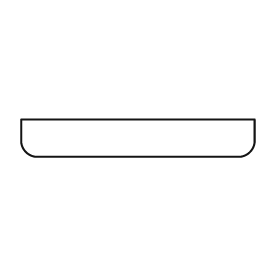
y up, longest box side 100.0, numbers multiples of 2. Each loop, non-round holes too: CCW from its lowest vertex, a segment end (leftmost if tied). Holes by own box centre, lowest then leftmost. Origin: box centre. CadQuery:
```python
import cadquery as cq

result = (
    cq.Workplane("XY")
    .moveTo(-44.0, -8.0)
    .lineTo(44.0, -8.0)
    .threePointArc((48.0, -6.0), (50.0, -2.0))
    .lineTo(50.0, 8.0)
    .lineTo(-50.0, 8.0)
    .lineTo(-50.0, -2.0)
    .threePointArc((-48.0, -6.0), (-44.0, -8.0))
    .close()
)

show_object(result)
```